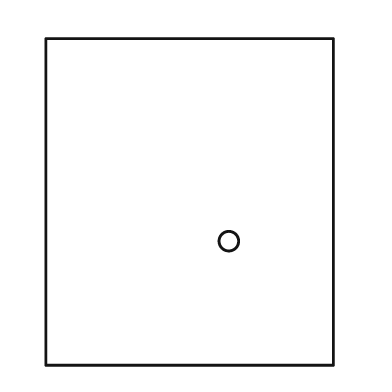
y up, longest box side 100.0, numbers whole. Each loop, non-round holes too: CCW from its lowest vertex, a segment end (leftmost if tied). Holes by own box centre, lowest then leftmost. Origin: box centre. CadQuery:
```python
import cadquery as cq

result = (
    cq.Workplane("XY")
    .moveTo(-44.0, -50.0)
    .lineTo(44.0, -50.0)
    .lineTo(44.0, 50.0)
    .lineTo(-44.0, 50.0)
    .close()
    .moveTo(12.0, -12.0)
    .circle(3.0)
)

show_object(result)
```